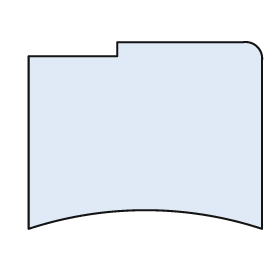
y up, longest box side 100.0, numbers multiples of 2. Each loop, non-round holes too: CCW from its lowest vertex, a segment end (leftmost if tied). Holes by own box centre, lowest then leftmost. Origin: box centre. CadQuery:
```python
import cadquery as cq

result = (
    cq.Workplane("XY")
    .moveTo(-50.0, -40.0)
    .threePointArc((0.0, -32.0), (50.0, -40.0))
    .lineTo(50.0, 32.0)
    .threePointArc((48.0, 38.0), (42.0, 40.0))
    .lineTo(-12.0, 40.0)
    .lineTo(-12.0, 34.0)
    .lineTo(-50.0, 34.0)
    .close()
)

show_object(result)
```